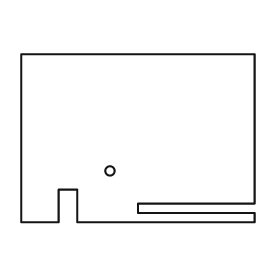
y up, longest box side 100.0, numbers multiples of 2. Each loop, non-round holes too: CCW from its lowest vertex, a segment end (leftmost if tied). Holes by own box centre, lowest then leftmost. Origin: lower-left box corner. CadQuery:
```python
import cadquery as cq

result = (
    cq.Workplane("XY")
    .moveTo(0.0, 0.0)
    .lineTo(16.0, 0.0)
    .lineTo(16.0, 14.0)
    .lineTo(24.0, 14.0)
    .lineTo(24.0, 0.0)
    .lineTo(100.0, 0.0)
    .lineTo(100.0, 4.0)
    .lineTo(50.0, 4.0)
    .lineTo(50.0, 8.0)
    .lineTo(100.0, 8.0)
    .lineTo(100.0, 72.0)
    .lineTo(0.0, 72.0)
    .close()
    .moveTo(38.0, 22.0)
    .circle(2.0)
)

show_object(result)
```